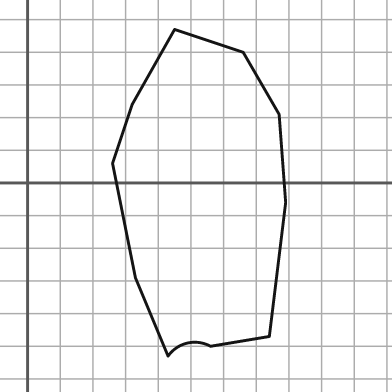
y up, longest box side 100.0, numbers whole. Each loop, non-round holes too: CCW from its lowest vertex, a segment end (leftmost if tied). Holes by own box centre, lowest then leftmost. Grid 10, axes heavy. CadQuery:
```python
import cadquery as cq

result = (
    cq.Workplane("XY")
    .moveTo(43.0, -53.0)
    .threePointArc((49.0, -49.0), (56.0, -50.0))
    .lineTo(74.0, -47.0)
    .lineTo(79.0, -6.0)
    .lineTo(77.0, 21.0)
    .lineTo(66.0, 40.0)
    .lineTo(45.0, 47.0)
    .lineTo(32.0, 24.0)
    .lineTo(26.0, 6.0)
    .lineTo(33.0, -29.0)
    .close()
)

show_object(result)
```